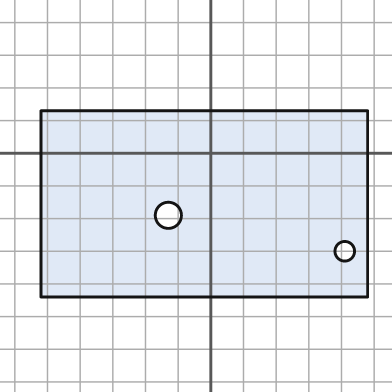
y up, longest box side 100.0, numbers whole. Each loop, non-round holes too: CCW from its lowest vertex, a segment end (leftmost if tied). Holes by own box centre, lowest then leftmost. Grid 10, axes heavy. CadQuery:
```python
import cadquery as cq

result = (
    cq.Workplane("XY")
    .moveTo(-52.0, -44.0)
    .lineTo(48.0, -44.0)
    .lineTo(48.0, 13.0)
    .lineTo(-52.0, 13.0)
    .close()
    .moveTo(41.0, -30.0)
    .circle(3.0)
    .moveTo(-13.0, -19.0)
    .circle(4.0)
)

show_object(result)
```